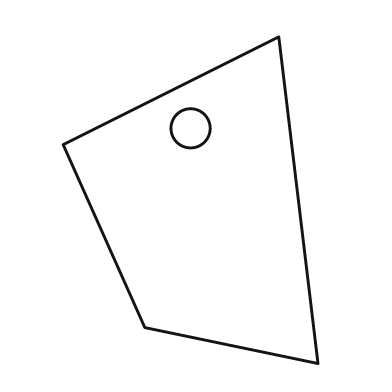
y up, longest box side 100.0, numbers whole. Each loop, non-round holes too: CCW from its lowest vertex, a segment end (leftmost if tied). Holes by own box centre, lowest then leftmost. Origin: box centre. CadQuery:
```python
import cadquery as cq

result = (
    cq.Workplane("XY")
    .moveTo(39.0, -50.0)
    .lineTo(27.0, 50.0)
    .lineTo(-39.0, 17.0)
    .lineTo(-14.0, -39.0)
    .close()
    .moveTo(0.0, 22.0)
    .circle(6.0)
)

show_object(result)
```